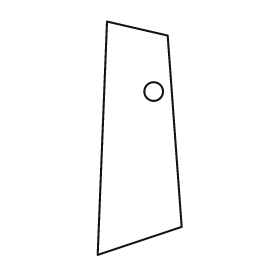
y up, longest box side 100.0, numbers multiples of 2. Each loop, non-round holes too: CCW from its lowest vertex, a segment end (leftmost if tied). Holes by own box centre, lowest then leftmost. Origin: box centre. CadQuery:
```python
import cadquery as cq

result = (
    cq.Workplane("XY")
    .moveTo(-18.0, -50.0)
    .lineTo(18.0, -38.0)
    .lineTo(12.0, 44.0)
    .lineTo(-14.0, 50.0)
    .close()
    .moveTo(6.0, 20.0)
    .circle(4.0)
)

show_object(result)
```